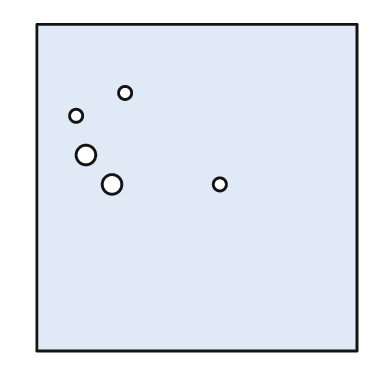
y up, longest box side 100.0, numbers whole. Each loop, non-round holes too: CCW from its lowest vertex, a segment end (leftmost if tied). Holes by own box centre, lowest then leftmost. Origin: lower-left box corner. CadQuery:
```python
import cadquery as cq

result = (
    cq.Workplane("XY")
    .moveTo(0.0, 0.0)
    .lineTo(98.0, 0.0)
    .lineTo(98.0, 100.0)
    .lineTo(0.0, 100.0)
    .close()
    .moveTo(23.0, 51.0)
    .circle(3.0)
    .moveTo(56.0, 51.0)
    .circle(2.0)
    .moveTo(15.0, 60.0)
    .circle(3.0)
    .moveTo(12.0, 72.0)
    .circle(2.0)
    .moveTo(27.0, 79.0)
    .circle(2.0)
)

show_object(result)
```